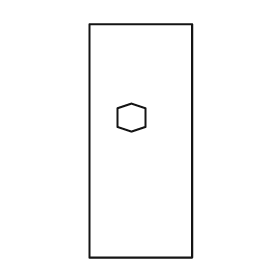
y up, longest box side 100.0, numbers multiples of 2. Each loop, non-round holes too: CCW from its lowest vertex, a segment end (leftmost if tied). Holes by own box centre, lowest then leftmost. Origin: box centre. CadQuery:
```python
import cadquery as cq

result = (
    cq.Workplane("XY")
    .moveTo(-22.0, -50.0)
    .lineTo(22.0, -50.0)
    .lineTo(22.0, 50.0)
    .lineTo(-22.0, 50.0)
    .close()
    .moveTo(-4.0, 4.0)
    .lineTo(2.0, 6.0)
    .lineTo(2.0, 14.0)
    .lineTo(-4.0, 16.0)
    .lineTo(-10.0, 14.0)
    .lineTo(-10.0, 6.0)
    .close()
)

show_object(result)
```